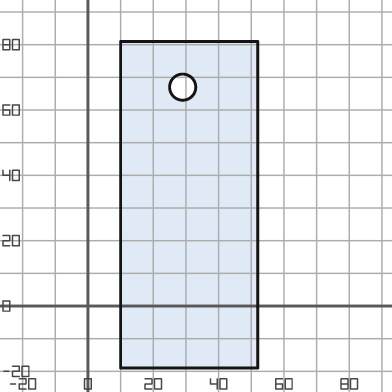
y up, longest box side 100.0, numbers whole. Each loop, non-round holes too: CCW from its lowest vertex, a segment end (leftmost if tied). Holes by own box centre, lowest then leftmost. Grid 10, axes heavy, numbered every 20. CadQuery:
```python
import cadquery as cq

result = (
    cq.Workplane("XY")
    .moveTo(10.0, -19.0)
    .lineTo(52.0, -19.0)
    .lineTo(52.0, 81.0)
    .lineTo(10.0, 81.0)
    .close()
    .moveTo(29.0, 67.0)
    .circle(4.0)
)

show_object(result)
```